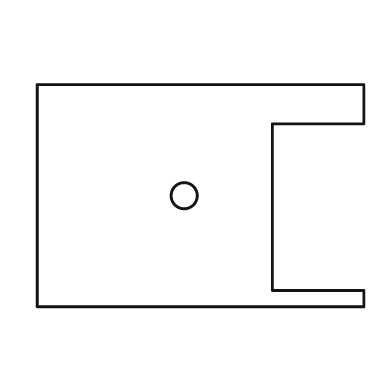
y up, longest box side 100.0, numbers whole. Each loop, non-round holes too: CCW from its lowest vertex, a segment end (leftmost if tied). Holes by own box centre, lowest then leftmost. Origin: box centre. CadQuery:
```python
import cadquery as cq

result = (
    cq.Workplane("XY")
    .moveTo(-50.0, -34.0)
    .lineTo(50.0, -34.0)
    .lineTo(50.0, -29.0)
    .lineTo(22.0, -29.0)
    .lineTo(22.0, 22.0)
    .lineTo(50.0, 22.0)
    .lineTo(50.0, 34.0)
    .lineTo(-50.0, 34.0)
    .close()
    .moveTo(-5.0, 0.0)
    .circle(4.0)
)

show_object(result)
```